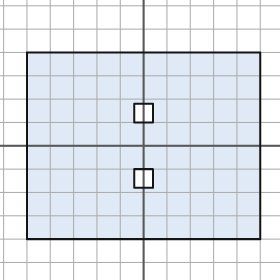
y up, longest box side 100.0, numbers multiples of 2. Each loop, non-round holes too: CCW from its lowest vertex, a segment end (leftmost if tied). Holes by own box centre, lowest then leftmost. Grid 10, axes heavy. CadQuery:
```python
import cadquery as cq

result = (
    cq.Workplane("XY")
    .moveTo(-50.0, -40.0)
    .lineTo(50.0, -40.0)
    .lineTo(50.0, 40.0)
    .lineTo(-50.0, 40.0)
    .close()
    .moveTo(-4.0, -18.0)
    .lineTo(4.0, -18.0)
    .lineTo(4.0, -10.0)
    .lineTo(-4.0, -10.0)
    .close()
    .moveTo(-4.0, 10.0)
    .lineTo(4.0, 10.0)
    .lineTo(4.0, 18.0)
    .lineTo(-4.0, 18.0)
    .close()
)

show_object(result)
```